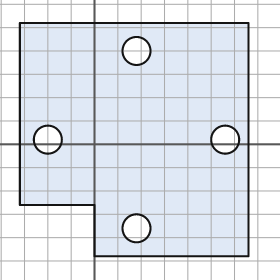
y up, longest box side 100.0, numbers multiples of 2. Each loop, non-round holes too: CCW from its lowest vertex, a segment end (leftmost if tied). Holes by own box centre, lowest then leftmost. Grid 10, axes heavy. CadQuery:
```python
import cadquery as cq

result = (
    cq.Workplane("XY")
    .moveTo(0.0, -48.0)
    .lineTo(66.0, -48.0)
    .lineTo(66.0, 52.0)
    .lineTo(-32.0, 52.0)
    .lineTo(-32.0, -26.0)
    .lineTo(0.0, -26.0)
    .close()
    .moveTo(18.0, -36.0)
    .circle(6.0)
    .moveTo(-20.0, 2.0)
    .circle(6.0)
    .moveTo(56.0, 2.0)
    .circle(6.0)
    .moveTo(18.0, 40.0)
    .circle(6.0)
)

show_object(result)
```